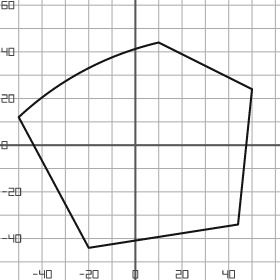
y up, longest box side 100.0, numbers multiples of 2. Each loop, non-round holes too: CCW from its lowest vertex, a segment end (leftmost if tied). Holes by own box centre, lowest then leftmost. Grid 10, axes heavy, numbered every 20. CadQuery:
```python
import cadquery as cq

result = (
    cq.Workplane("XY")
    .moveTo(-20.0, -44.0)
    .lineTo(44.0, -34.0)
    .lineTo(50.0, 24.0)
    .lineTo(10.0, 44.0)
    .threePointArc((-22.0, 32.0), (-50.0, 12.0))
    .close()
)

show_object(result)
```